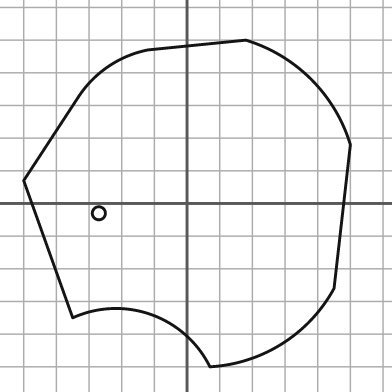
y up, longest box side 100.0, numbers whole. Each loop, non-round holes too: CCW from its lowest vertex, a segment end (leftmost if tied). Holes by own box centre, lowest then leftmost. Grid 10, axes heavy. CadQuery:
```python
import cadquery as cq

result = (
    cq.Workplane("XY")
    .moveTo(7.0, -50.0)
    .threePointArc((29.0, -43.0), (45.0, -26.0))
    .lineTo(50.0, 18.0)
    .threePointArc((38.0, 38.0), (18.0, 50.0))
    .lineTo(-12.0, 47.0)
    .threePointArc((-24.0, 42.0), (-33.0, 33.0))
    .lineTo(-50.0, 7.0)
    .lineTo(-35.0, -35.0)
    .threePointArc((-11.0, -34.0), (7.0, -50.0))
    .close()
    .moveTo(-27.0, -3.0)
    .circle(2.0)
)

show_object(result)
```